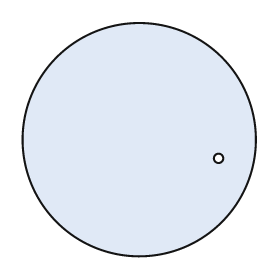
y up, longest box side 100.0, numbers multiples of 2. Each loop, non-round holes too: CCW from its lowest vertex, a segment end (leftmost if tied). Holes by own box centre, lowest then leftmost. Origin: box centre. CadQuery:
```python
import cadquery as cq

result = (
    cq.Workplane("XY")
    .moveTo(0.0, 0.0)
    .circle(50.0)
    .moveTo(34.0, -8.0)
    .circle(2.0)
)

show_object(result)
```